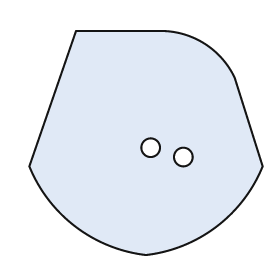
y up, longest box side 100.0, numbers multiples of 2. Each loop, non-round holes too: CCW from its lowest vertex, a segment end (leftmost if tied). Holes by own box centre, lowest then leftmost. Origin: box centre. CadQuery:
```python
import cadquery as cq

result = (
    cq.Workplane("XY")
    .moveTo(0.0, -48.0)
    .threePointArc((30.0, -36.0), (50.0, -10.0))
    .lineTo(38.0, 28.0)
    .threePointArc((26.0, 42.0), (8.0, 48.0))
    .lineTo(-30.0, 48.0)
    .lineTo(-50.0, -10.0)
    .threePointArc((-30.0, -36.0), (0.0, -48.0))
    .close()
    .moveTo(16.0, -6.0)
    .circle(4.0)
    .moveTo(2.0, -2.0)
    .circle(4.0)
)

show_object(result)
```